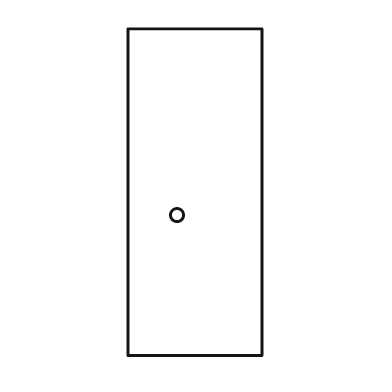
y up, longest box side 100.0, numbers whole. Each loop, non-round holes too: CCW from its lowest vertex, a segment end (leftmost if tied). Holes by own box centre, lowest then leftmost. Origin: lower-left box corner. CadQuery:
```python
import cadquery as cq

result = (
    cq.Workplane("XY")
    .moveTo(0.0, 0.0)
    .lineTo(41.0, 0.0)
    .lineTo(41.0, 100.0)
    .lineTo(0.0, 100.0)
    .close()
    .moveTo(15.0, 43.0)
    .circle(2.0)
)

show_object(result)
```